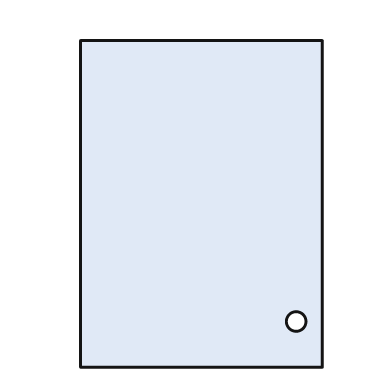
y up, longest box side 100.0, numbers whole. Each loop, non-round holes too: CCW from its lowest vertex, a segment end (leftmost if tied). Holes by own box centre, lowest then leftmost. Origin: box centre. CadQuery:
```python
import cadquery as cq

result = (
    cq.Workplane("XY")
    .moveTo(-37.0, -50.0)
    .lineTo(37.0, -50.0)
    .lineTo(37.0, 50.0)
    .lineTo(-37.0, 50.0)
    .close()
    .moveTo(29.0, -36.0)
    .circle(3.0)
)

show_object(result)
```